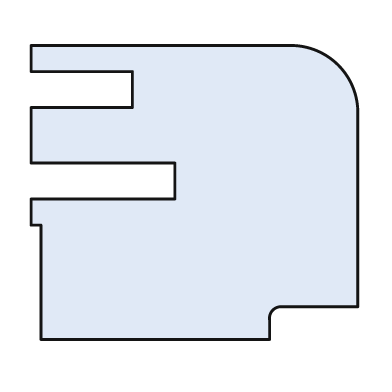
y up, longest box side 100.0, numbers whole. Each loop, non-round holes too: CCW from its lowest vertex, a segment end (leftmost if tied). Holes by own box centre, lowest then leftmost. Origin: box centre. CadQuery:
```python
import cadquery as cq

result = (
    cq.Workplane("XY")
    .moveTo(-47.0, -45.0)
    .lineTo(23.0, -45.0)
    .lineTo(23.0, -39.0)
    .threePointArc((24.0, -36.0), (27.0, -35.0))
    .lineTo(50.0, -35.0)
    .lineTo(50.0, 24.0)
    .threePointArc((44.0, 39.0), (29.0, 45.0))
    .lineTo(-50.0, 45.0)
    .lineTo(-50.0, 37.0)
    .lineTo(-19.0, 37.0)
    .lineTo(-19.0, 26.0)
    .lineTo(-50.0, 26.0)
    .lineTo(-50.0, 9.0)
    .lineTo(-6.0, 9.0)
    .lineTo(-6.0, -2.0)
    .lineTo(-50.0, -2.0)
    .lineTo(-50.0, -10.0)
    .lineTo(-47.0, -10.0)
    .close()
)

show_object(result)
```